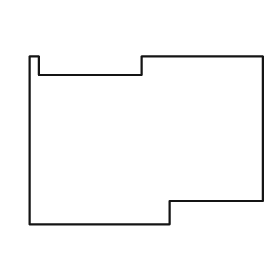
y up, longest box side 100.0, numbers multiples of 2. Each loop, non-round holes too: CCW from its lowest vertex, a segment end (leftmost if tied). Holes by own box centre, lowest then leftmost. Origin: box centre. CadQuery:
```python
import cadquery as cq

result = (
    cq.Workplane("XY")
    .moveTo(-50.0, -36.0)
    .lineTo(10.0, -36.0)
    .lineTo(10.0, -26.0)
    .lineTo(50.0, -26.0)
    .lineTo(50.0, 36.0)
    .lineTo(-2.0, 36.0)
    .lineTo(-2.0, 28.0)
    .lineTo(-46.0, 28.0)
    .lineTo(-46.0, 36.0)
    .lineTo(-50.0, 36.0)
    .close()
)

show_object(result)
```